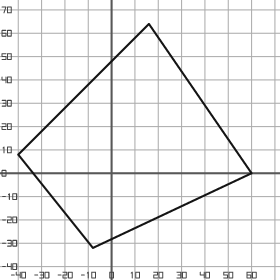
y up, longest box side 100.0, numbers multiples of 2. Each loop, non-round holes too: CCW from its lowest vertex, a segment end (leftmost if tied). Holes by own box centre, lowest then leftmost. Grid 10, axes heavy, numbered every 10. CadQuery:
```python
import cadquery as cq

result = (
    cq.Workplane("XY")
    .moveTo(-8.0, -32.0)
    .lineTo(60.0, 0.0)
    .lineTo(16.0, 64.0)
    .lineTo(-40.0, 8.0)
    .close()
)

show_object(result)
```